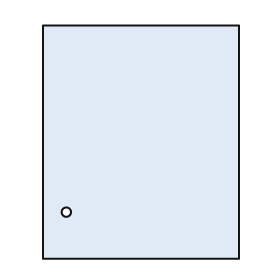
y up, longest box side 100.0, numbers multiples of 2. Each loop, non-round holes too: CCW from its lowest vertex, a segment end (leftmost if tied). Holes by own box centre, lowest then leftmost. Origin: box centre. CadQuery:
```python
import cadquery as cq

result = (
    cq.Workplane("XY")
    .moveTo(-42.0, -50.0)
    .lineTo(42.0, -50.0)
    .lineTo(42.0, 50.0)
    .lineTo(-42.0, 50.0)
    .close()
    .moveTo(-32.0, -30.0)
    .circle(2.0)
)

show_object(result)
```